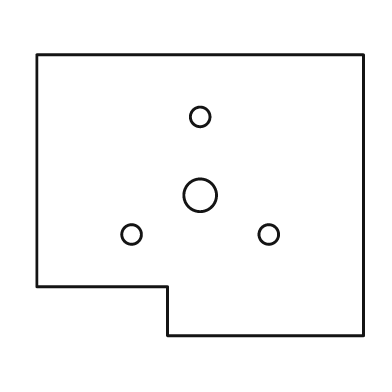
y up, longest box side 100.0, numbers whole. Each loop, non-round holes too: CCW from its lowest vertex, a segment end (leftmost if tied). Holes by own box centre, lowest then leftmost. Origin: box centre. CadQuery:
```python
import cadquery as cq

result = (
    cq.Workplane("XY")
    .moveTo(-10.0, -43.0)
    .lineTo(50.0, -43.0)
    .lineTo(50.0, 43.0)
    .lineTo(-50.0, 43.0)
    .lineTo(-50.0, -28.0)
    .lineTo(-10.0, -28.0)
    .close()
    .moveTo(-21.0, -12.0)
    .circle(3.0)
    .moveTo(21.0, -12.0)
    .circle(3.0)
    .moveTo(0.0, 0.0)
    .circle(5.0)
    .moveTo(0.0, 24.0)
    .circle(3.0)
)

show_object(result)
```